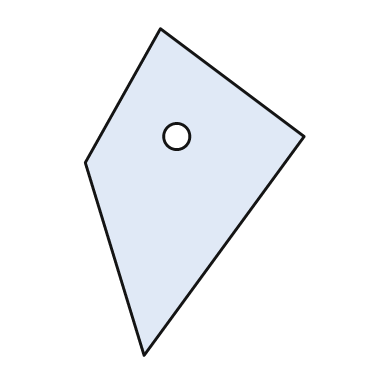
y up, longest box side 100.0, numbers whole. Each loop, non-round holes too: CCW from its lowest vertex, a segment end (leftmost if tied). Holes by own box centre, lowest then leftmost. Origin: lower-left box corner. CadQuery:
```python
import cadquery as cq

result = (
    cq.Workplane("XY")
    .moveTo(18.0, 0.0)
    .lineTo(67.0, 67.0)
    .lineTo(23.0, 100.0)
    .lineTo(0.0, 59.0)
    .close()
    .moveTo(28.0, 67.0)
    .circle(4.0)
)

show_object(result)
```